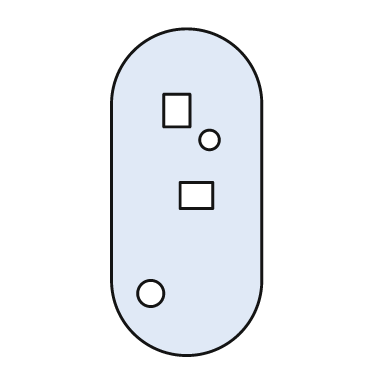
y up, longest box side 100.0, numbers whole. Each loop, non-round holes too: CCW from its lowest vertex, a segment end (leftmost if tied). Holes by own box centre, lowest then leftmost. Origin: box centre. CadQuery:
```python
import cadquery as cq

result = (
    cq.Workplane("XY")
    .moveTo(-23.0, -27.0)
    .threePointArc((0.0, -50.0), (23.0, -27.0))
    .lineTo(23.0, 27.0)
    .threePointArc((0.0, 50.0), (-23.0, 27.0))
    .close()
    .moveTo(-11.0, -31.0)
    .circle(4.0)
    .moveTo(-2.0, -5.0)
    .lineTo(8.0, -5.0)
    .lineTo(8.0, 3.0)
    .lineTo(-2.0, 3.0)
    .close()
    .moveTo(7.0, 16.0)
    .circle(3.0)
    .moveTo(-7.0, 20.0)
    .lineTo(1.0, 20.0)
    .lineTo(1.0, 30.0)
    .lineTo(-7.0, 30.0)
    .close()
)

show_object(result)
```